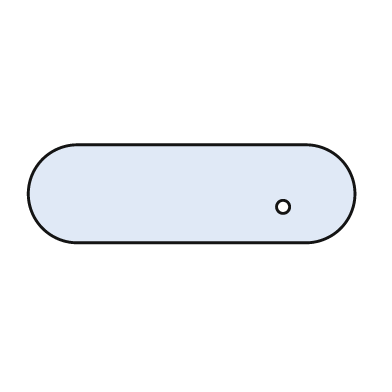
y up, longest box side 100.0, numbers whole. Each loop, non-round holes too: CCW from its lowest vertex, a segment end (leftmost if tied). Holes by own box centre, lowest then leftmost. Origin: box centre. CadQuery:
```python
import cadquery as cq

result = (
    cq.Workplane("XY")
    .moveTo(-35.0, -15.0)
    .lineTo(35.0, -15.0)
    .threePointArc((50.0, 0.0), (35.0, 15.0))
    .lineTo(-35.0, 15.0)
    .threePointArc((-50.0, 0.0), (-35.0, -15.0))
    .close()
    .moveTo(28.0, -4.0)
    .circle(2.0)
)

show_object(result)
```